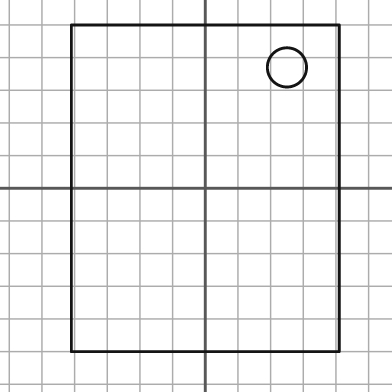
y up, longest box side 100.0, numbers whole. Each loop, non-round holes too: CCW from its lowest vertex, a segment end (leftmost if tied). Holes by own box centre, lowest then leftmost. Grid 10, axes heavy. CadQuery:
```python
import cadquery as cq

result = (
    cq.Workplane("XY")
    .moveTo(-41.0, -50.0)
    .lineTo(41.0, -50.0)
    .lineTo(41.0, 50.0)
    .lineTo(-41.0, 50.0)
    .close()
    .moveTo(25.0, 37.0)
    .circle(6.0)
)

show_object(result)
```